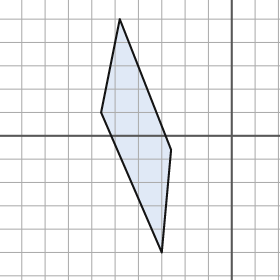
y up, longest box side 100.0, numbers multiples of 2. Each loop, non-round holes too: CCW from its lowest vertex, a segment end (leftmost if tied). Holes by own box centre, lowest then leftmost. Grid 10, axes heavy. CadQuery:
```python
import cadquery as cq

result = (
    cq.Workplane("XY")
    .moveTo(-30.0, -50.0)
    .lineTo(-26.0, -6.0)
    .lineTo(-48.0, 50.0)
    .lineTo(-56.0, 10.0)
    .close()
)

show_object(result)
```